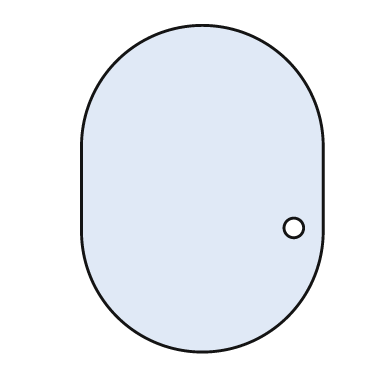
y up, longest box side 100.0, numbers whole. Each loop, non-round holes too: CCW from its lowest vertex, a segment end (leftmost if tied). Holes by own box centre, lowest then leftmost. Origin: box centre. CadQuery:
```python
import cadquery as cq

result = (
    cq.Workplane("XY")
    .moveTo(-37.0, -13.0)
    .threePointArc((0.0, -50.0), (37.0, -13.0))
    .lineTo(37.0, 13.0)
    .threePointArc((0.0, 50.0), (-37.0, 13.0))
    .close()
    .moveTo(28.0, -12.0)
    .circle(3.0)
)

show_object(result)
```